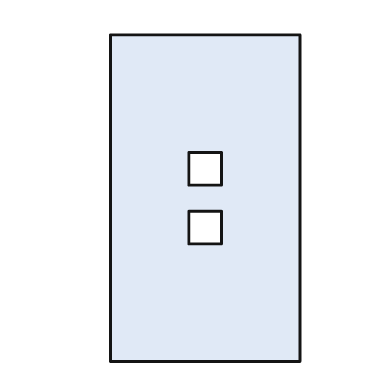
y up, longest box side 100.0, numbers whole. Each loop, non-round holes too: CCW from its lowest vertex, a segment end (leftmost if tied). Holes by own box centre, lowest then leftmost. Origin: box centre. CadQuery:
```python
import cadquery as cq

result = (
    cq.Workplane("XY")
    .moveTo(-29.0, -50.0)
    .lineTo(29.0, -50.0)
    .lineTo(29.0, 50.0)
    .lineTo(-29.0, 50.0)
    .close()
    .moveTo(-5.0, -14.0)
    .lineTo(5.0, -14.0)
    .lineTo(5.0, -4.0)
    .lineTo(-5.0, -4.0)
    .close()
    .moveTo(-5.0, 4.0)
    .lineTo(5.0, 4.0)
    .lineTo(5.0, 14.0)
    .lineTo(-5.0, 14.0)
    .close()
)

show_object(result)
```